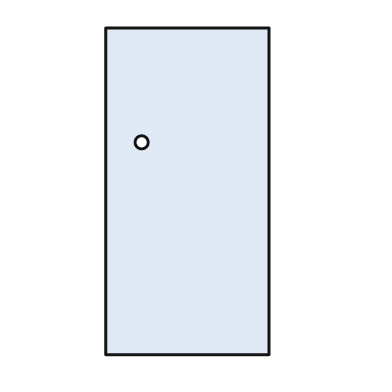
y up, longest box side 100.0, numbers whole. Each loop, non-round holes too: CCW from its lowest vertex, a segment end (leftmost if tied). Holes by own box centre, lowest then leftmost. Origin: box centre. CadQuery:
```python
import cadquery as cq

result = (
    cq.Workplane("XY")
    .moveTo(-25.0, -50.0)
    .lineTo(25.0, -50.0)
    .lineTo(25.0, 50.0)
    .lineTo(-25.0, 50.0)
    .close()
    .moveTo(-14.0, 15.0)
    .circle(2.0)
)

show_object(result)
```